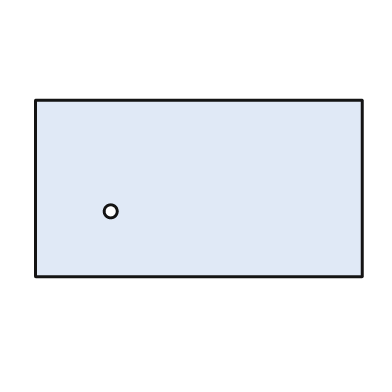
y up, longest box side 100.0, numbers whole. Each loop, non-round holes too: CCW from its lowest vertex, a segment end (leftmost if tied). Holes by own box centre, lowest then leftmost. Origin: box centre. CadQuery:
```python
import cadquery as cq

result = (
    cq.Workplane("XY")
    .moveTo(-50.0, -27.0)
    .lineTo(50.0, -27.0)
    .lineTo(50.0, 27.0)
    .lineTo(-50.0, 27.0)
    .close()
    .moveTo(-27.0, -7.0)
    .circle(2.0)
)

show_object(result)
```